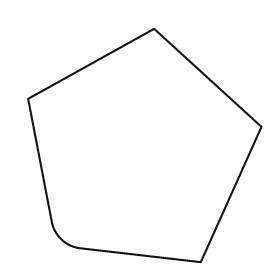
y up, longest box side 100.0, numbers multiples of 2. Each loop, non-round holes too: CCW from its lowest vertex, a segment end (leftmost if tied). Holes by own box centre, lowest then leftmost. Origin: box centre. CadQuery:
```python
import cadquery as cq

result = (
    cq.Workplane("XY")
    .moveTo(24.0, -50.0)
    .lineTo(50.0, 8.0)
    .lineTo(4.0, 50.0)
    .lineTo(-50.0, 20.0)
    .lineTo(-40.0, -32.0)
    .threePointArc((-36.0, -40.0), (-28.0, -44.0))
    .close()
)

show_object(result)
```